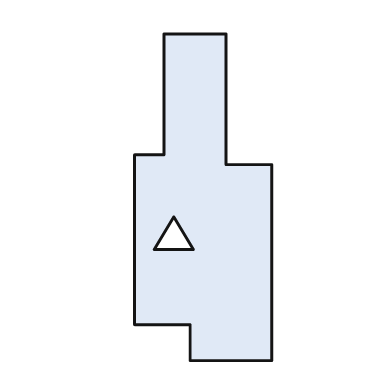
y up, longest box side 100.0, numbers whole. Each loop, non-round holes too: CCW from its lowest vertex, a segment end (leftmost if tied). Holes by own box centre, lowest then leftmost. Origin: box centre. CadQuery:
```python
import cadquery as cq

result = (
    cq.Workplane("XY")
    .moveTo(-4.0, -50.0)
    .lineTo(21.0, -50.0)
    .lineTo(21.0, 10.0)
    .lineTo(7.0, 10.0)
    .lineTo(7.0, 50.0)
    .lineTo(-12.0, 50.0)
    .lineTo(-12.0, 13.0)
    .lineTo(-21.0, 13.0)
    .lineTo(-21.0, -39.0)
    .lineTo(-4.0, -39.0)
    .close()
    .moveTo(-15.0, -16.0)
    .lineTo(-3.0, -16.0)
    .lineTo(-9.0, -6.0)
    .close()
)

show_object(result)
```